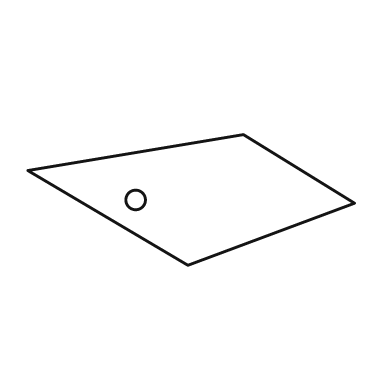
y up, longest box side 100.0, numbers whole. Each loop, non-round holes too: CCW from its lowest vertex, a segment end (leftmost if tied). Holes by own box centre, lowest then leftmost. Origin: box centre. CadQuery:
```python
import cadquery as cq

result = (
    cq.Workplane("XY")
    .moveTo(-1.0, -20.0)
    .lineTo(50.0, -1.0)
    .lineTo(16.0, 20.0)
    .lineTo(-50.0, 9.0)
    .close()
    .moveTo(-17.0, 0.0)
    .circle(3.0)
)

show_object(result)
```